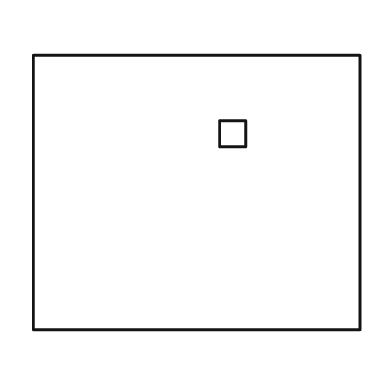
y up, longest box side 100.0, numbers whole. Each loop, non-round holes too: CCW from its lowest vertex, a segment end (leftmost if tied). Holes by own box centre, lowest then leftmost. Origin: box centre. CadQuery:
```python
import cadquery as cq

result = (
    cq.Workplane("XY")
    .moveTo(-50.0, -42.0)
    .lineTo(50.0, -42.0)
    .lineTo(50.0, 42.0)
    .lineTo(-50.0, 42.0)
    .close()
    .moveTo(7.0, 14.0)
    .lineTo(15.0, 14.0)
    .lineTo(15.0, 22.0)
    .lineTo(7.0, 22.0)
    .close()
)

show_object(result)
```